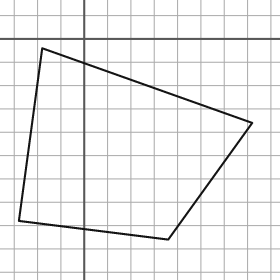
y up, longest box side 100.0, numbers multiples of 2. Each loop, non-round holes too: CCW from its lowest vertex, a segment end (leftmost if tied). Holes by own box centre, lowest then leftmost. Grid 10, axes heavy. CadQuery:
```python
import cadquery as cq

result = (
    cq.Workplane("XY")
    .moveTo(36.0, -86.0)
    .lineTo(72.0, -36.0)
    .lineTo(-18.0, -4.0)
    .lineTo(-28.0, -78.0)
    .close()
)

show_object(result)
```